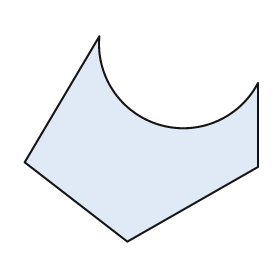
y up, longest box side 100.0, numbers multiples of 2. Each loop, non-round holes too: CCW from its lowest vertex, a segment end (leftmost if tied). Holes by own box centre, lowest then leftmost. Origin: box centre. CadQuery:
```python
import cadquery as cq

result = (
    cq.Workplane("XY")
    .moveTo(-6.0, -44.0)
    .lineTo(50.0, -12.0)
    .lineTo(50.0, 24.0)
    .threePointArc((8.0, 6.0), (-18.0, 44.0))
    .lineTo(-50.0, -10.0)
    .close()
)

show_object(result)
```